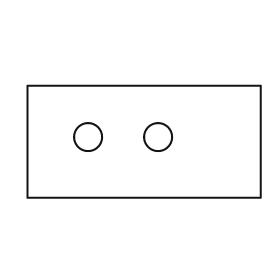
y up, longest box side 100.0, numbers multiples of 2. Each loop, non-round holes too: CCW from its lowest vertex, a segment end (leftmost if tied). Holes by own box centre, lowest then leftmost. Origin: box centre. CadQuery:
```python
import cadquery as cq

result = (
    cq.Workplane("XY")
    .moveTo(-50.0, -24.0)
    .lineTo(50.0, -24.0)
    .lineTo(50.0, 24.0)
    .lineTo(-50.0, 24.0)
    .close()
    .moveTo(-24.0, 2.0)
    .circle(6.0)
    .moveTo(6.0, 2.0)
    .circle(6.0)
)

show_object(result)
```